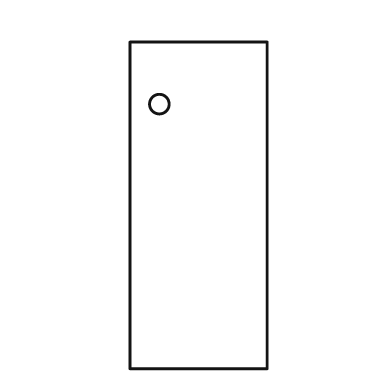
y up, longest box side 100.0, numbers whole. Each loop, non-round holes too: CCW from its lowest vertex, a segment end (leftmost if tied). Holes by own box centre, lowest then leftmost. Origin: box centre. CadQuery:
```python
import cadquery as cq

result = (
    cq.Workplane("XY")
    .moveTo(-21.0, -50.0)
    .lineTo(21.0, -50.0)
    .lineTo(21.0, 50.0)
    .lineTo(-21.0, 50.0)
    .close()
    .moveTo(-12.0, 31.0)
    .circle(3.0)
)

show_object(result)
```